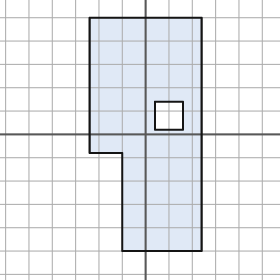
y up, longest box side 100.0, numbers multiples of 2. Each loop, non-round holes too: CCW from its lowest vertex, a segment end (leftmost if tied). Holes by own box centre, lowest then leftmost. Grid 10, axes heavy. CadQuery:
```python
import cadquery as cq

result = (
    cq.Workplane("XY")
    .moveTo(-10.0, -50.0)
    .lineTo(24.0, -50.0)
    .lineTo(24.0, 50.0)
    .lineTo(-24.0, 50.0)
    .lineTo(-24.0, -8.0)
    .lineTo(-10.0, -8.0)
    .close()
    .moveTo(4.0, 2.0)
    .lineTo(16.0, 2.0)
    .lineTo(16.0, 14.0)
    .lineTo(4.0, 14.0)
    .close()
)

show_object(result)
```